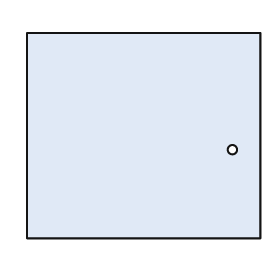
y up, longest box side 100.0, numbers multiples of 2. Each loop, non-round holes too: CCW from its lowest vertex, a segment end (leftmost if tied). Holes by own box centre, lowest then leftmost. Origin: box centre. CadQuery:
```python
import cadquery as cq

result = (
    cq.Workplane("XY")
    .moveTo(-50.0, -44.0)
    .lineTo(50.0, -44.0)
    .lineTo(50.0, 44.0)
    .lineTo(-50.0, 44.0)
    .close()
    .moveTo(38.0, -6.0)
    .circle(2.0)
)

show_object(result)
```